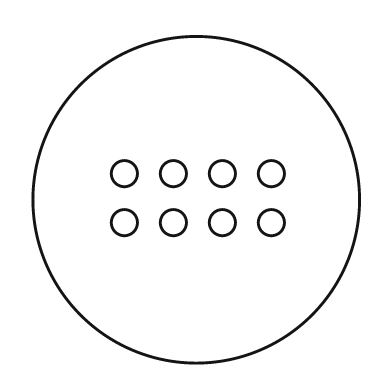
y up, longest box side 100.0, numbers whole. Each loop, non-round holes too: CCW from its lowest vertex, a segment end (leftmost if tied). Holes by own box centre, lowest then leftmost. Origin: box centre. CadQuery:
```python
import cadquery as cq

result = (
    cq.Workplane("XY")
    .moveTo(0.0, 0.0)
    .circle(50.0)
    .moveTo(-22.0, -7.0)
    .circle(4.0)
    .moveTo(-7.0, -7.0)
    .circle(4.0)
    .moveTo(8.0, -7.0)
    .circle(4.0)
    .moveTo(23.0, -7.0)
    .circle(4.0)
    .moveTo(-22.0, 8.0)
    .circle(4.0)
    .moveTo(-7.0, 8.0)
    .circle(4.0)
    .moveTo(8.0, 8.0)
    .circle(4.0)
    .moveTo(23.0, 8.0)
    .circle(4.0)
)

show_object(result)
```